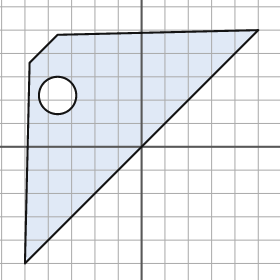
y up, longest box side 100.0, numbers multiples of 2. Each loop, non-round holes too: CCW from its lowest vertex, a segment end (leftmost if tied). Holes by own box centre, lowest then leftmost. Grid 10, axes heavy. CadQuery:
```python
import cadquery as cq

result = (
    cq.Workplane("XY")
    .moveTo(-50.0, -50.0)
    .lineTo(50.0, 50.0)
    .lineTo(-36.0, 48.0)
    .lineTo(-48.0, 36.0)
    .close()
    .moveTo(-36.0, 22.0)
    .circle(8.0)
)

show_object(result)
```